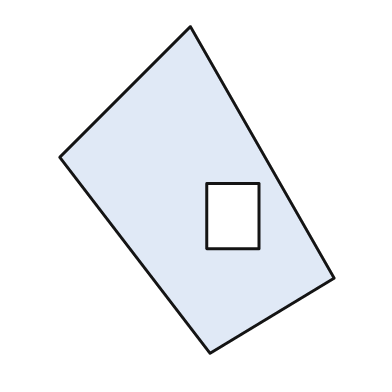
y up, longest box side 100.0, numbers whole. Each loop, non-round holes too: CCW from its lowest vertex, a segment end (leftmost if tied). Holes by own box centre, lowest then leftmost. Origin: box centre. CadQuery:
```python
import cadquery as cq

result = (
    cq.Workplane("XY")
    .moveTo(4.0, -50.0)
    .lineTo(42.0, -27.0)
    .lineTo(-2.0, 50.0)
    .lineTo(-42.0, 10.0)
    .close()
    .moveTo(3.0, -18.0)
    .lineTo(19.0, -18.0)
    .lineTo(19.0, 2.0)
    .lineTo(3.0, 2.0)
    .close()
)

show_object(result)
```